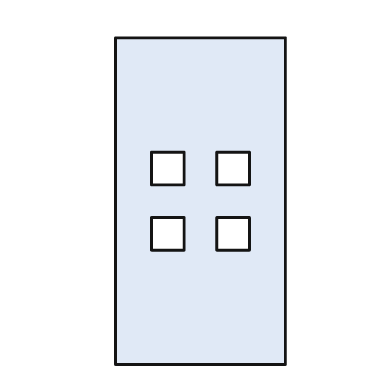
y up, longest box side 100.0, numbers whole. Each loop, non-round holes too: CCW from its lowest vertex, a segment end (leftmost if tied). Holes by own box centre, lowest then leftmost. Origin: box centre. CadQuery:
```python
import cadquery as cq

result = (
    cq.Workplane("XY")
    .moveTo(-26.0, -50.0)
    .lineTo(26.0, -50.0)
    .lineTo(26.0, 50.0)
    .lineTo(-26.0, 50.0)
    .close()
    .moveTo(-15.0, -15.0)
    .lineTo(-5.0, -15.0)
    .lineTo(-5.0, -5.0)
    .lineTo(-15.0, -5.0)
    .close()
    .moveTo(5.0, -15.0)
    .lineTo(15.0, -15.0)
    .lineTo(15.0, -5.0)
    .lineTo(5.0, -5.0)
    .close()
    .moveTo(-15.0, 5.0)
    .lineTo(-5.0, 5.0)
    .lineTo(-5.0, 15.0)
    .lineTo(-15.0, 15.0)
    .close()
    .moveTo(5.0, 5.0)
    .lineTo(15.0, 5.0)
    .lineTo(15.0, 15.0)
    .lineTo(5.0, 15.0)
    .close()
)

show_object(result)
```